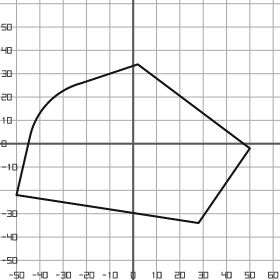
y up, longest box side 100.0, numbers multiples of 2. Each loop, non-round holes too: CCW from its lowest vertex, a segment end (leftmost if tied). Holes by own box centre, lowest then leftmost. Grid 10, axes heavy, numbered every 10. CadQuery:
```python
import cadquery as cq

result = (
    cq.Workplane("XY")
    .moveTo(28.0, -34.0)
    .lineTo(50.0, -2.0)
    .lineTo(2.0, 34.0)
    .lineTo(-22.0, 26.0)
    .threePointArc((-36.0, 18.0), (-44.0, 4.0))
    .lineTo(-50.0, -22.0)
    .close()
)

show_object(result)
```